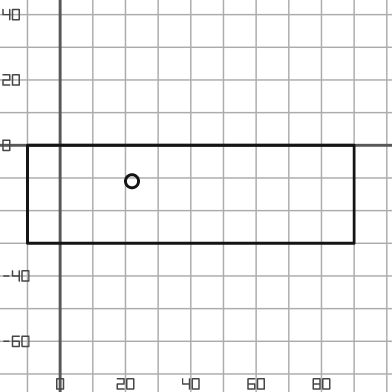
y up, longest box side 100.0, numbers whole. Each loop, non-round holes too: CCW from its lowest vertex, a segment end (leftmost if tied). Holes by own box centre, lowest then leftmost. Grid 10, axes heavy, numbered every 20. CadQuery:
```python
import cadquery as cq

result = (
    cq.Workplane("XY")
    .moveTo(-10.0, -30.0)
    .lineTo(90.0, -30.0)
    .lineTo(90.0, 0.0)
    .lineTo(-10.0, 0.0)
    .close()
    .moveTo(22.0, -11.0)
    .circle(2.0)
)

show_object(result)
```